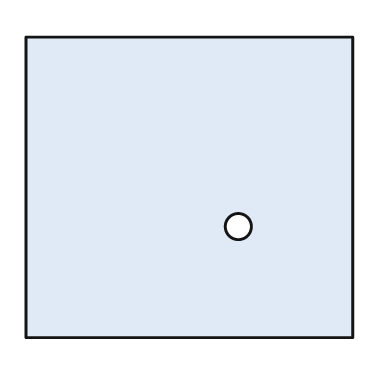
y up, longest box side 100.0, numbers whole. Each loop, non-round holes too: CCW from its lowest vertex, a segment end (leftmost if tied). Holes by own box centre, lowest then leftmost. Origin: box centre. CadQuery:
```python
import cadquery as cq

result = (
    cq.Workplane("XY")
    .moveTo(-50.0, -46.0)
    .lineTo(50.0, -46.0)
    .lineTo(50.0, 46.0)
    .lineTo(-50.0, 46.0)
    .close()
    .moveTo(15.0, -12.0)
    .circle(4.0)
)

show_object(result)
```